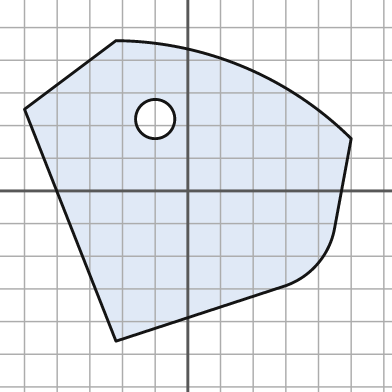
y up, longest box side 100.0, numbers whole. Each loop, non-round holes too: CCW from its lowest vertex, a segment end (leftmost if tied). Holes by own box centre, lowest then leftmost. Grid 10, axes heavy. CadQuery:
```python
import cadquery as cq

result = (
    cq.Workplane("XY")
    .moveTo(-22.0, -46.0)
    .lineTo(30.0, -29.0)
    .threePointArc((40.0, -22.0), (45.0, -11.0))
    .lineTo(50.0, 16.0)
    .threePointArc((17.0, 38.0), (-22.0, 46.0))
    .lineTo(-50.0, 25.0)
    .close()
    .moveTo(-10.0, 22.0)
    .circle(6.0)
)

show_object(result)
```